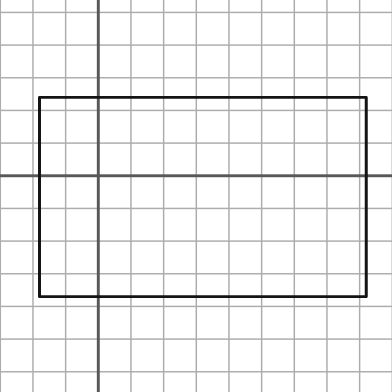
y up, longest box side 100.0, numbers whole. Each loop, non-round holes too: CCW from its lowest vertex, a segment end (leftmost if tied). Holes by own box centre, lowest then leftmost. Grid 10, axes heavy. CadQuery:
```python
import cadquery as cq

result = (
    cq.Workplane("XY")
    .moveTo(-18.0, -37.0)
    .lineTo(82.0, -37.0)
    .lineTo(82.0, 24.0)
    .lineTo(-18.0, 24.0)
    .close()
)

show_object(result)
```